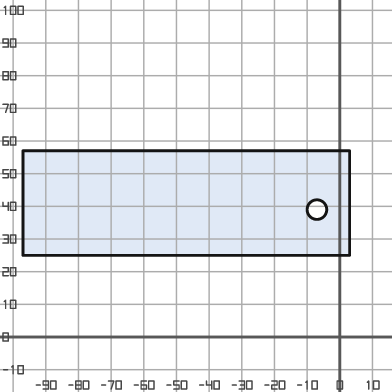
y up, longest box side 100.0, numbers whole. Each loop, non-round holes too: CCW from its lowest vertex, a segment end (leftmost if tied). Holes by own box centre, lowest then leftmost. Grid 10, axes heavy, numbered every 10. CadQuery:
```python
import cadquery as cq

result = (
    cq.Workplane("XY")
    .moveTo(-97.0, 25.0)
    .lineTo(3.0, 25.0)
    .lineTo(3.0, 57.0)
    .lineTo(-97.0, 57.0)
    .close()
    .moveTo(-7.0, 39.0)
    .circle(3.0)
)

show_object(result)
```